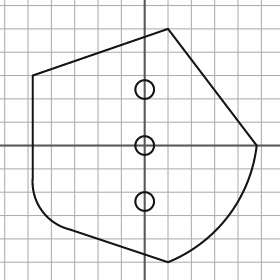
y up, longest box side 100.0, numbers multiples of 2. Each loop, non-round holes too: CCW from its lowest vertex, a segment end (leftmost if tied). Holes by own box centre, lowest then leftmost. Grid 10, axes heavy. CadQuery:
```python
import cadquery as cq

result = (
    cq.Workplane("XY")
    .moveTo(10.0, -50.0)
    .threePointArc((36.0, -30.0), (48.0, 0.0))
    .lineTo(10.0, 50.0)
    .lineTo(-48.0, 30.0)
    .lineTo(-48.0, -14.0)
    .threePointArc((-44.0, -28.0), (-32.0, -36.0))
    .close()
    .moveTo(0.0, -24.0)
    .circle(4.0)
    .moveTo(0.0, 0.0)
    .circle(4.0)
    .moveTo(0.0, 24.0)
    .circle(4.0)
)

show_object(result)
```